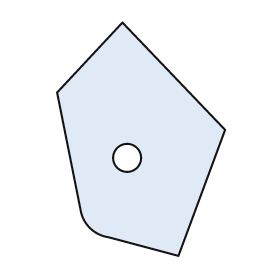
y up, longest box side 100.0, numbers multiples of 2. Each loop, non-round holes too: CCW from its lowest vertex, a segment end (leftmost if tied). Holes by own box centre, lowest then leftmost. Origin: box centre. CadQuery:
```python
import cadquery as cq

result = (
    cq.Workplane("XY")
    .moveTo(16.0, -50.0)
    .lineTo(36.0, 4.0)
    .lineTo(-8.0, 50.0)
    .lineTo(-36.0, 20.0)
    .lineTo(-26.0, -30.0)
    .threePointArc((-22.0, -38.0), (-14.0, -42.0))
    .close()
    .moveTo(-6.0, -8.0)
    .circle(6.0)
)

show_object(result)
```